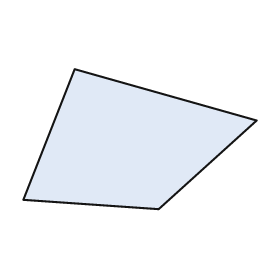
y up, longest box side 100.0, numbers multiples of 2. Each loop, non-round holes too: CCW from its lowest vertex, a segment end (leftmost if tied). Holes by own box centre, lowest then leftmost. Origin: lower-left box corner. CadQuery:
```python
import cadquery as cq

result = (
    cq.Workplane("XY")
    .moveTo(58.0, 0.0)
    .lineTo(100.0, 38.0)
    .lineTo(22.0, 60.0)
    .lineTo(0.0, 4.0)
    .close()
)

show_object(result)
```